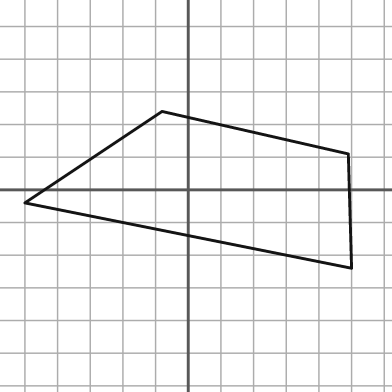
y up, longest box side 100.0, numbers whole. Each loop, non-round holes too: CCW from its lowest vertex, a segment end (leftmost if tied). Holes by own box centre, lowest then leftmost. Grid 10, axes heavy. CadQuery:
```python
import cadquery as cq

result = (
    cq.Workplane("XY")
    .moveTo(50.0, -24.0)
    .lineTo(49.0, 11.0)
    .lineTo(-8.0, 24.0)
    .lineTo(-50.0, -4.0)
    .close()
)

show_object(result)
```